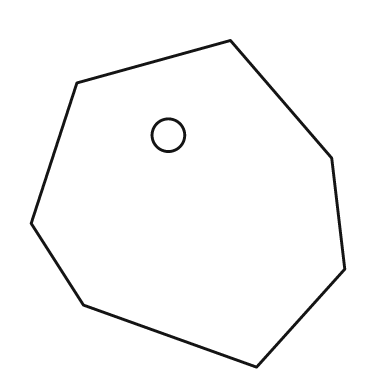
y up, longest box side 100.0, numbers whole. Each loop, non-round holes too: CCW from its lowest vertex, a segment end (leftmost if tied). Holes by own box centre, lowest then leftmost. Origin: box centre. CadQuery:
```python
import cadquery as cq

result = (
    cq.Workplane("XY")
    .moveTo(21.0, -50.0)
    .lineTo(48.0, -20.0)
    .lineTo(44.0, 14.0)
    .lineTo(13.0, 50.0)
    .lineTo(-34.0, 37.0)
    .lineTo(-48.0, -6.0)
    .lineTo(-32.0, -31.0)
    .close()
    .moveTo(-6.0, 21.0)
    .circle(5.0)
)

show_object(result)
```